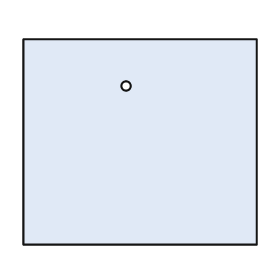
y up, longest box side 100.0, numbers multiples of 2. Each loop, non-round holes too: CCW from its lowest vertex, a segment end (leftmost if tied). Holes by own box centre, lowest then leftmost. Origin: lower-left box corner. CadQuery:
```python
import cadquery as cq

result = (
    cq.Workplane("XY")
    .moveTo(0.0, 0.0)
    .lineTo(100.0, 0.0)
    .lineTo(100.0, 88.0)
    .lineTo(0.0, 88.0)
    .close()
    .moveTo(44.0, 68.0)
    .circle(2.0)
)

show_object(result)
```